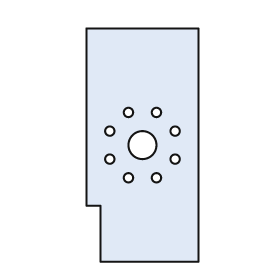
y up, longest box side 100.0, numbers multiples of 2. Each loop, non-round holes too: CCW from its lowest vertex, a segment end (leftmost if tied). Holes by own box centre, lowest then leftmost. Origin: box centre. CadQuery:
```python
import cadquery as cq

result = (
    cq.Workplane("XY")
    .moveTo(-18.0, -50.0)
    .lineTo(24.0, -50.0)
    .lineTo(24.0, 50.0)
    .lineTo(-24.0, 50.0)
    .lineTo(-24.0, -26.0)
    .lineTo(-18.0, -26.0)
    .close()
    .moveTo(-6.0, -14.0)
    .circle(2.0)
    .moveTo(6.0, -14.0)
    .circle(2.0)
    .moveTo(-14.0, -6.0)
    .circle(2.0)
    .moveTo(14.0, -6.0)
    .circle(2.0)
    .moveTo(0.0, 0.0)
    .circle(6.0)
    .moveTo(-14.0, 6.0)
    .circle(2.0)
    .moveTo(14.0, 6.0)
    .circle(2.0)
    .moveTo(-6.0, 14.0)
    .circle(2.0)
    .moveTo(6.0, 14.0)
    .circle(2.0)
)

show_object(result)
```